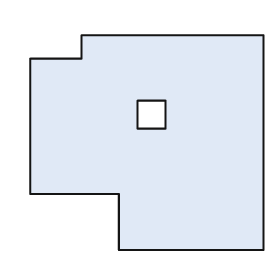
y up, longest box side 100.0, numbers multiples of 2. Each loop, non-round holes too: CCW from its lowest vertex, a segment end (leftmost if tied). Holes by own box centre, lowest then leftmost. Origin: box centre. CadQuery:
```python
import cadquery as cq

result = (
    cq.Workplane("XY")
    .moveTo(-12.0, -46.0)
    .lineTo(50.0, -46.0)
    .lineTo(50.0, 46.0)
    .lineTo(-28.0, 46.0)
    .lineTo(-28.0, 36.0)
    .lineTo(-50.0, 36.0)
    .lineTo(-50.0, -22.0)
    .lineTo(-12.0, -22.0)
    .close()
    .moveTo(-4.0, 6.0)
    .lineTo(8.0, 6.0)
    .lineTo(8.0, 18.0)
    .lineTo(-4.0, 18.0)
    .close()
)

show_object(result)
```